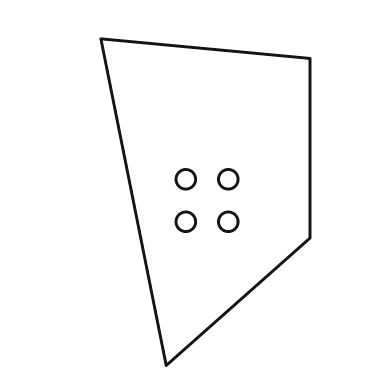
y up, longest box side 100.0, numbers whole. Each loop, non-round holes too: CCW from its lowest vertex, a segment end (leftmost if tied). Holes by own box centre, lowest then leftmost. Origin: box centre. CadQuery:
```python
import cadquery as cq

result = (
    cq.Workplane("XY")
    .moveTo(-12.0, -50.0)
    .lineTo(32.0, -11.0)
    .lineTo(32.0, 44.0)
    .lineTo(-32.0, 50.0)
    .close()
    .moveTo(-6.0, -6.0)
    .circle(3.0)
    .moveTo(7.0, -6.0)
    .circle(3.0)
    .moveTo(-6.0, 7.0)
    .circle(3.0)
    .moveTo(7.0, 7.0)
    .circle(3.0)
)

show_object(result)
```